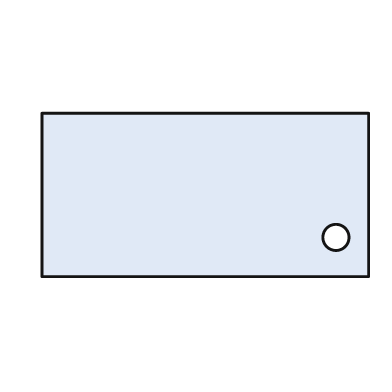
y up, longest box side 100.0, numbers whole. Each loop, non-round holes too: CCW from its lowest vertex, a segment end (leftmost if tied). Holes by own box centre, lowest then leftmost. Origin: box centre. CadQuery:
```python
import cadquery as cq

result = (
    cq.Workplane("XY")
    .moveTo(-50.0, -25.0)
    .lineTo(50.0, -25.0)
    .lineTo(50.0, 25.0)
    .lineTo(-50.0, 25.0)
    .close()
    .moveTo(40.0, -13.0)
    .circle(4.0)
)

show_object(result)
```